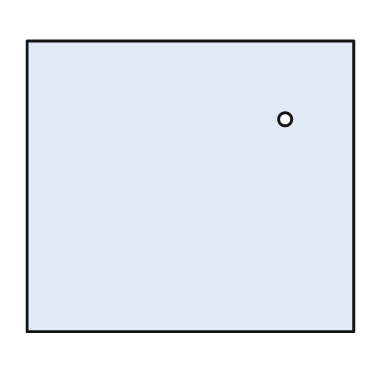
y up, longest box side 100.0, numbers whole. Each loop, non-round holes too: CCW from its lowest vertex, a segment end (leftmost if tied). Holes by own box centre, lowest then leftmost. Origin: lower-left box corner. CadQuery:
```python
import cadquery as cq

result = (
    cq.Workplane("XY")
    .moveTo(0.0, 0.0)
    .lineTo(100.0, 0.0)
    .lineTo(100.0, 89.0)
    .lineTo(0.0, 89.0)
    .close()
    .moveTo(79.0, 65.0)
    .circle(2.0)
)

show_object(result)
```